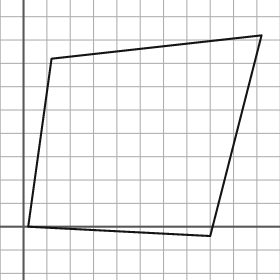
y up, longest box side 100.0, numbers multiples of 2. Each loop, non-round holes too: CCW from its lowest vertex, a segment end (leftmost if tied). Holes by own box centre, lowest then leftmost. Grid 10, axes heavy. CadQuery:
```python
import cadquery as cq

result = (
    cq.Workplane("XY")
    .moveTo(80.0, -4.0)
    .lineTo(102.0, 82.0)
    .lineTo(12.0, 72.0)
    .lineTo(2.0, 0.0)
    .close()
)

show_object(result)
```